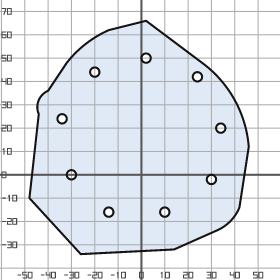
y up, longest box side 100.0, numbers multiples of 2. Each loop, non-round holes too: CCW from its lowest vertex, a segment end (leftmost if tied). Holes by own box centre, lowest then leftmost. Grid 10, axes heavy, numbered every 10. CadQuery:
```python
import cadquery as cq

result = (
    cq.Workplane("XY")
    .moveTo(-26.0, -34.0)
    .lineTo(14.0, -32.0)
    .lineTo(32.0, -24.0)
    .threePointArc((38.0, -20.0), (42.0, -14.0))
    .lineTo(46.0, 12.0)
    .threePointArc((40.0, 32.0), (26.0, 48.0))
    .lineTo(2.0, 66.0)
    .lineTo(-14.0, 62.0)
    .threePointArc((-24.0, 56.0), (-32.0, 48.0))
    .lineTo(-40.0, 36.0)
    .threePointArc((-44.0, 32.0), (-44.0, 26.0))
    .lineTo(-48.0, -10.0)
    .close()
    .moveTo(-14.0, -16.0)
    .circle(2.0)
    .moveTo(10.0, -16.0)
    .circle(2.0)
    .moveTo(30.0, -2.0)
    .circle(2.0)
    .moveTo(-30.0, 0.0)
    .circle(2.0)
    .moveTo(34.0, 20.0)
    .circle(2.0)
    .moveTo(-34.0, 24.0)
    .circle(2.0)
    .moveTo(24.0, 42.0)
    .circle(2.0)
    .moveTo(-20.0, 44.0)
    .circle(2.0)
    .moveTo(2.0, 50.0)
    .circle(2.0)
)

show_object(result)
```